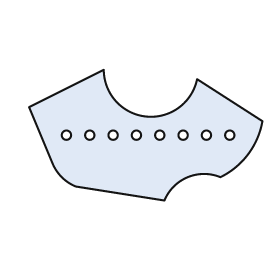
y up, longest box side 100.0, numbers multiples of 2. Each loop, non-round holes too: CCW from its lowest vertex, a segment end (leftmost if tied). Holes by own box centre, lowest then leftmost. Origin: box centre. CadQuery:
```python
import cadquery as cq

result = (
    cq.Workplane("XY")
    .moveTo(8.0, -28.0)
    .threePointArc((18.0, -18.0), (32.0, -18.0))
    .threePointArc((44.0, -8.0), (50.0, 6.0))
    .lineTo(22.0, 24.0)
    .threePointArc((0.0, 8.0), (-18.0, 28.0))
    .lineTo(-50.0, 12.0)
    .lineTo(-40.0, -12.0)
    .threePointArc((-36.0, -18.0), (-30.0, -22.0))
    .close()
    .moveTo(-34.0, 0.0)
    .circle(2.0)
    .moveTo(-24.0, 0.0)
    .circle(2.0)
    .moveTo(-14.0, 0.0)
    .circle(2.0)
    .moveTo(-4.0, 0.0)
    .circle(2.0)
    .moveTo(6.0, 0.0)
    .circle(2.0)
    .moveTo(16.0, 0.0)
    .circle(2.0)
    .moveTo(26.0, 0.0)
    .circle(2.0)
    .moveTo(36.0, 0.0)
    .circle(2.0)
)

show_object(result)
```